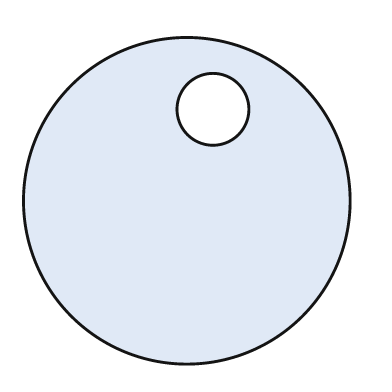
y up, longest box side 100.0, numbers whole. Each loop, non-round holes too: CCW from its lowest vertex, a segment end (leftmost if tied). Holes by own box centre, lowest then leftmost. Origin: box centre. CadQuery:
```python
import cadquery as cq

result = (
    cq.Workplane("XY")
    .moveTo(0.0, 0.0)
    .circle(50.0)
    .moveTo(8.0, 28.0)
    .circle(11.0)
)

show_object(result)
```